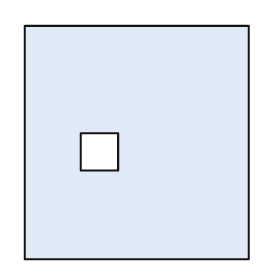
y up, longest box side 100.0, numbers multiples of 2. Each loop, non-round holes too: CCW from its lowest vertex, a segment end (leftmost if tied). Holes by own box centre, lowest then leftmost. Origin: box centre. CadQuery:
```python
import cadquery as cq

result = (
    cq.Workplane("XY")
    .moveTo(-48.0, -50.0)
    .lineTo(48.0, -50.0)
    .lineTo(48.0, 50.0)
    .lineTo(-48.0, 50.0)
    .close()
    .moveTo(-24.0, -12.0)
    .lineTo(-8.0, -12.0)
    .lineTo(-8.0, 4.0)
    .lineTo(-24.0, 4.0)
    .close()
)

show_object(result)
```